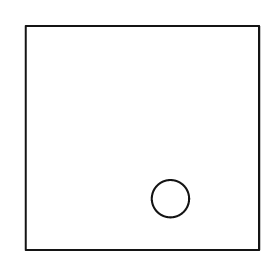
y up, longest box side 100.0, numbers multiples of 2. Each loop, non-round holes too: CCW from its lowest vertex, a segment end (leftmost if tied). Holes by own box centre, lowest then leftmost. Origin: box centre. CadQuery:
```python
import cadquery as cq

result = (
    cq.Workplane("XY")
    .moveTo(-50.0, -48.0)
    .lineTo(50.0, -48.0)
    .lineTo(50.0, 48.0)
    .lineTo(-50.0, 48.0)
    .close()
    .moveTo(12.0, -26.0)
    .circle(8.0)
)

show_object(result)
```